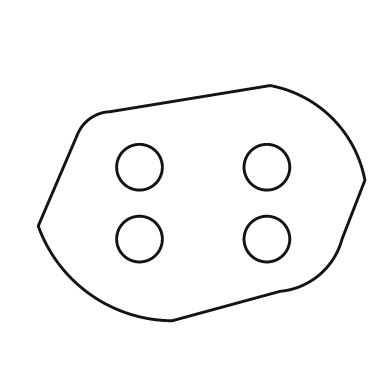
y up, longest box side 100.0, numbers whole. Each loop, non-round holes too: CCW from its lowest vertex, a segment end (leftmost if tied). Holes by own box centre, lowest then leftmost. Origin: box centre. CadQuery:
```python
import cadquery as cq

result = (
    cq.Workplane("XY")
    .moveTo(-9.0, -36.0)
    .lineTo(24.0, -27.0)
    .threePointArc((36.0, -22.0), (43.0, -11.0))
    .lineTo(50.0, 7.0)
    .threePointArc((40.0, 26.0), (21.0, 36.0))
    .lineTo(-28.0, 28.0)
    .threePointArc((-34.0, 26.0), (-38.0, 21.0))
    .lineTo(-50.0, -7.0)
    .threePointArc((-34.0, -28.0), (-9.0, -36.0))
    .close()
    .moveTo(-19.0, -11.0)
    .circle(7.0)
    .moveTo(20.0, -11.0)
    .circle(7.0)
    .moveTo(-19.0, 11.0)
    .circle(7.0)
    .moveTo(20.0, 11.0)
    .circle(7.0)
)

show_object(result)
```